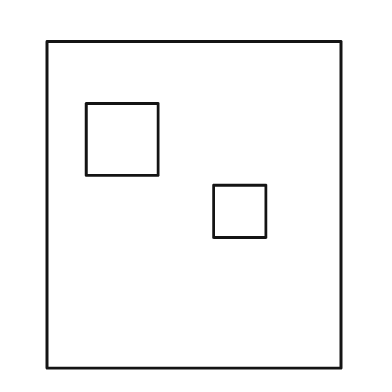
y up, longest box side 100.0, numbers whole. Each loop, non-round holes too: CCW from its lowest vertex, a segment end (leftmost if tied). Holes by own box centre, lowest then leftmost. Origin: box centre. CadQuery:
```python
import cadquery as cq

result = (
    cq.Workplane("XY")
    .moveTo(-45.0, -50.0)
    .lineTo(45.0, -50.0)
    .lineTo(45.0, 50.0)
    .lineTo(-45.0, 50.0)
    .close()
    .moveTo(6.0, -10.0)
    .lineTo(22.0, -10.0)
    .lineTo(22.0, 6.0)
    .lineTo(6.0, 6.0)
    .close()
    .moveTo(-33.0, 9.0)
    .lineTo(-11.0, 9.0)
    .lineTo(-11.0, 31.0)
    .lineTo(-33.0, 31.0)
    .close()
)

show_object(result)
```